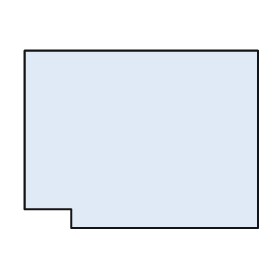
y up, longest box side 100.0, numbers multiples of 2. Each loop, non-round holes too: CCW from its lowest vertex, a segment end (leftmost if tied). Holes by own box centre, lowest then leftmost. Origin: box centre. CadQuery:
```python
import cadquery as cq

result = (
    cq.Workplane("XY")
    .moveTo(-30.0, -38.0)
    .lineTo(50.0, -38.0)
    .lineTo(50.0, 38.0)
    .lineTo(-50.0, 38.0)
    .lineTo(-50.0, -30.0)
    .lineTo(-30.0, -30.0)
    .close()
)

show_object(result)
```